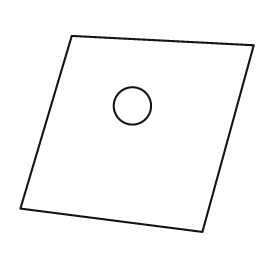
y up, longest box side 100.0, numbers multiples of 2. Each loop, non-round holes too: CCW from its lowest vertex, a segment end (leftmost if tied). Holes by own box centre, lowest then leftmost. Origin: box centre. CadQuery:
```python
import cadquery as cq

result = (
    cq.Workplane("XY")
    .moveTo(28.0, -42.0)
    .lineTo(50.0, 38.0)
    .lineTo(-28.0, 42.0)
    .lineTo(-50.0, -32.0)
    .close()
    .moveTo(-2.0, 12.0)
    .circle(8.0)
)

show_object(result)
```